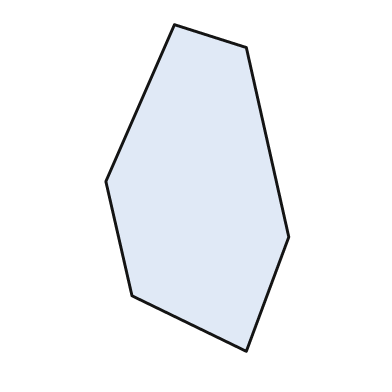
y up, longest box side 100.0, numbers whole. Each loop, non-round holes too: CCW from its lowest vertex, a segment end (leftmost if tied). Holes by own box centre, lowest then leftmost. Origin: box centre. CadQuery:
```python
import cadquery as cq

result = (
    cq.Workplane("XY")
    .moveTo(15.0, -50.0)
    .lineTo(28.0, -15.0)
    .lineTo(15.0, 43.0)
    .lineTo(-7.0, 50.0)
    .lineTo(-28.0, 2.0)
    .lineTo(-20.0, -33.0)
    .close()
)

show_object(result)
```